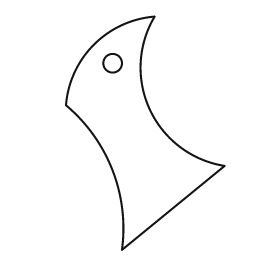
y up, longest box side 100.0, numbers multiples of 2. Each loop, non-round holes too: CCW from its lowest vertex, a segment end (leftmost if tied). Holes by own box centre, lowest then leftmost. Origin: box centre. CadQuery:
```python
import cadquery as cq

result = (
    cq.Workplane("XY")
    .moveTo(-10.0, -50.0)
    .lineTo(34.0, -14.0)
    .threePointArc((2.0, 10.0), (4.0, 50.0))
    .threePointArc((-22.0, 38.0), (-34.0, 12.0))
    .threePointArc((-14.0, -16.0), (-10.0, -50.0))
    .close()
    .moveTo(-14.0, 30.0)
    .circle(4.0)
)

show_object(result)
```